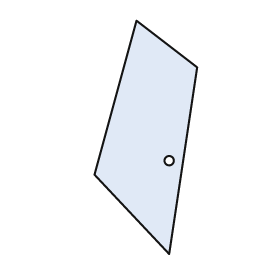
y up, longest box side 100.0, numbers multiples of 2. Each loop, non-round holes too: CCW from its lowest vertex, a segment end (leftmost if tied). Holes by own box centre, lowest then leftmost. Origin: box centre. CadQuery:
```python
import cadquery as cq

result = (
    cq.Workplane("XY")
    .moveTo(10.0, -50.0)
    .lineTo(22.0, 30.0)
    .lineTo(-4.0, 50.0)
    .lineTo(-22.0, -16.0)
    .close()
    .moveTo(10.0, -10.0)
    .circle(2.0)
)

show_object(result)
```